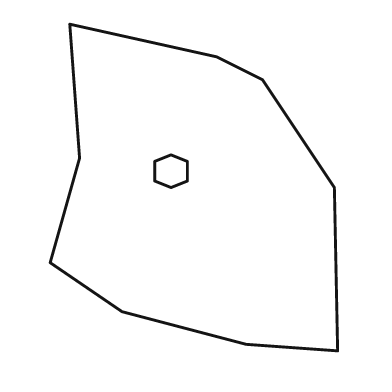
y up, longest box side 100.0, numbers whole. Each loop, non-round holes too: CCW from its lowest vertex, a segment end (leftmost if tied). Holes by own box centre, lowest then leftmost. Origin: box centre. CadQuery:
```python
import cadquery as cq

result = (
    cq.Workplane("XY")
    .moveTo(44.0, -50.0)
    .lineTo(43.0, 0.0)
    .lineTo(21.0, 33.0)
    .lineTo(7.0, 40.0)
    .lineTo(-38.0, 50.0)
    .lineTo(-35.0, 9.0)
    .lineTo(-44.0, -23.0)
    .lineTo(-22.0, -38.0)
    .lineTo(16.0, -48.0)
    .close()
    .moveTo(-7.0, 0.0)
    .lineTo(-2.0, 2.0)
    .lineTo(-2.0, 8.0)
    .lineTo(-7.0, 10.0)
    .lineTo(-12.0, 8.0)
    .lineTo(-12.0, 2.0)
    .close()
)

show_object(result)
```